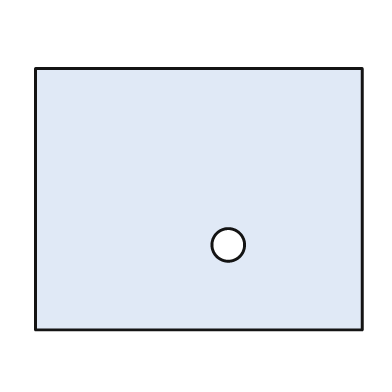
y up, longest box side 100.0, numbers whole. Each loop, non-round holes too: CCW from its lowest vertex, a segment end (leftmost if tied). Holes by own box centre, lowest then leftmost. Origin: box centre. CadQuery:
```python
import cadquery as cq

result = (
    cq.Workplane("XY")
    .moveTo(-50.0, -40.0)
    .lineTo(50.0, -40.0)
    .lineTo(50.0, 40.0)
    .lineTo(-50.0, 40.0)
    .close()
    .moveTo(9.0, -14.0)
    .circle(5.0)
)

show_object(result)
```